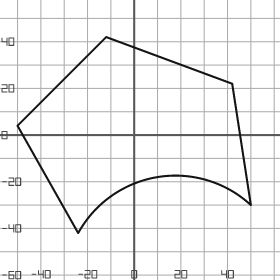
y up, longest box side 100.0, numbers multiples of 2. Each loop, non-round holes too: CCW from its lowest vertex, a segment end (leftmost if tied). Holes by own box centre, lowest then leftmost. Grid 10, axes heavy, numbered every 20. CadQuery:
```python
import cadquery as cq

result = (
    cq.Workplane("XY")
    .moveTo(-24.0, -42.0)
    .threePointArc((10.0, -18.0), (50.0, -30.0))
    .lineTo(42.0, 22.0)
    .lineTo(-12.0, 42.0)
    .lineTo(-50.0, 4.0)
    .close()
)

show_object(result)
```